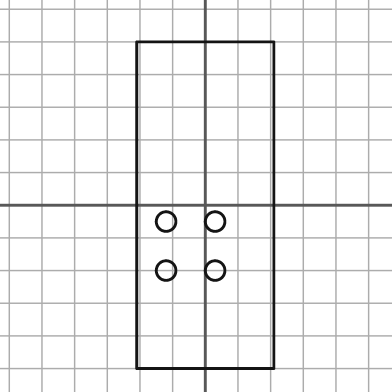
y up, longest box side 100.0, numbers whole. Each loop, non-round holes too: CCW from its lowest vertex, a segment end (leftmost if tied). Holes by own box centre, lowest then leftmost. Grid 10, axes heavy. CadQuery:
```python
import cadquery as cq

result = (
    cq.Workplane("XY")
    .moveTo(-21.0, -50.0)
    .lineTo(21.0, -50.0)
    .lineTo(21.0, 50.0)
    .lineTo(-21.0, 50.0)
    .close()
    .moveTo(-12.0, -20.0)
    .circle(3.0)
    .moveTo(3.0, -20.0)
    .circle(3.0)
    .moveTo(-12.0, -5.0)
    .circle(3.0)
    .moveTo(3.0, -5.0)
    .circle(3.0)
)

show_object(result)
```